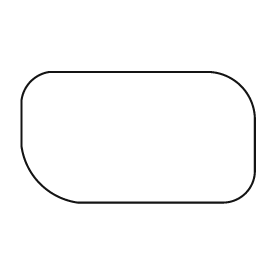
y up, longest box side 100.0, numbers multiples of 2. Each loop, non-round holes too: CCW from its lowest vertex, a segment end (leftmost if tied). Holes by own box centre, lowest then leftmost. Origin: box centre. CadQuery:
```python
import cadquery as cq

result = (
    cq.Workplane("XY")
    .moveTo(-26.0, -28.0)
    .lineTo(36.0, -28.0)
    .threePointArc((46.0, -24.0), (50.0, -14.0))
    .lineTo(50.0, 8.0)
    .threePointArc((44.0, 22.0), (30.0, 28.0))
    .lineTo(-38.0, 28.0)
    .threePointArc((-46.0, 24.0), (-50.0, 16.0))
    .lineTo(-50.0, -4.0)
    .threePointArc((-42.0, -20.0), (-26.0, -28.0))
    .close()
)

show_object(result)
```